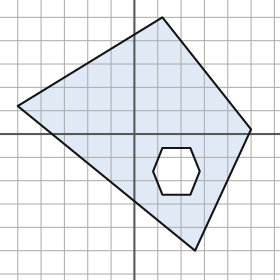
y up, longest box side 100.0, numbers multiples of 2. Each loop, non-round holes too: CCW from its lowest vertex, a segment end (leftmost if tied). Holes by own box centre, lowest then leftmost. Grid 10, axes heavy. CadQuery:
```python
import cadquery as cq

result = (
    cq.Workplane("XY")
    .moveTo(26.0, -50.0)
    .lineTo(50.0, 2.0)
    .lineTo(12.0, 50.0)
    .lineTo(-50.0, 12.0)
    .close()
    .moveTo(12.0, -26.0)
    .lineTo(24.0, -26.0)
    .lineTo(28.0, -16.0)
    .lineTo(24.0, -6.0)
    .lineTo(12.0, -6.0)
    .lineTo(8.0, -16.0)
    .close()
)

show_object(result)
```